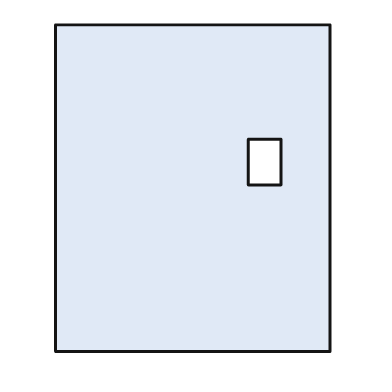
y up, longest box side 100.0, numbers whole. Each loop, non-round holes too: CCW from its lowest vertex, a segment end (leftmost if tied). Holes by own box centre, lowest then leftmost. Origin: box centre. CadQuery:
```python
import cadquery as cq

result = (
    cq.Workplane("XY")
    .moveTo(-42.0, -50.0)
    .lineTo(42.0, -50.0)
    .lineTo(42.0, 50.0)
    .lineTo(-42.0, 50.0)
    .close()
    .moveTo(17.0, 1.0)
    .lineTo(27.0, 1.0)
    .lineTo(27.0, 15.0)
    .lineTo(17.0, 15.0)
    .close()
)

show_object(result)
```